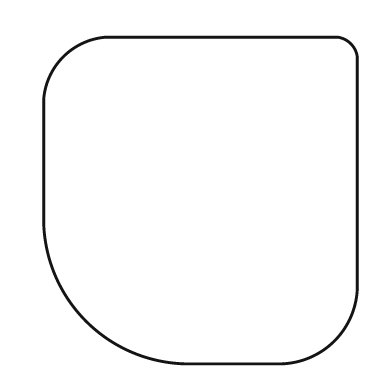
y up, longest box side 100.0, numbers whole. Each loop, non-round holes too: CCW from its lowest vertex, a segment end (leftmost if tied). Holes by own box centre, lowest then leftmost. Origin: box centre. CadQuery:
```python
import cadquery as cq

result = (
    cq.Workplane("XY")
    .moveTo(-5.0, -50.0)
    .lineTo(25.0, -50.0)
    .threePointArc((41.0, -43.0), (48.0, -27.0))
    .lineTo(48.0, 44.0)
    .threePointArc((46.0, 48.0), (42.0, 50.0))
    .lineTo(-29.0, 50.0)
    .threePointArc((-42.0, 44.0), (-48.0, 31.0))
    .lineTo(-48.0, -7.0)
    .threePointArc((-35.0, -37.0), (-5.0, -50.0))
    .close()
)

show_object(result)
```